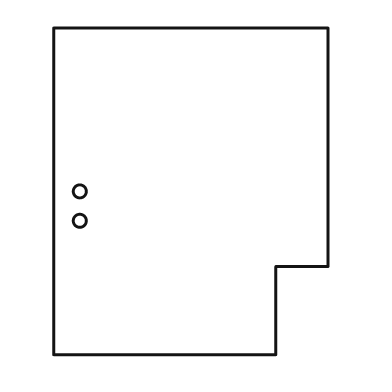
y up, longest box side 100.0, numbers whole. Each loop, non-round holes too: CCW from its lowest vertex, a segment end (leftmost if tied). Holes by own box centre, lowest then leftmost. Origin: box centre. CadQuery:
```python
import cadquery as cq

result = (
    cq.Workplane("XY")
    .moveTo(-42.0, -50.0)
    .lineTo(26.0, -50.0)
    .lineTo(26.0, -23.0)
    .lineTo(42.0, -23.0)
    .lineTo(42.0, 50.0)
    .lineTo(-42.0, 50.0)
    .close()
    .moveTo(-34.0, -9.0)
    .circle(2.0)
    .moveTo(-34.0, 0.0)
    .circle(2.0)
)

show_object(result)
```